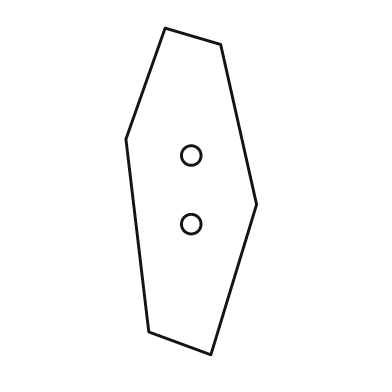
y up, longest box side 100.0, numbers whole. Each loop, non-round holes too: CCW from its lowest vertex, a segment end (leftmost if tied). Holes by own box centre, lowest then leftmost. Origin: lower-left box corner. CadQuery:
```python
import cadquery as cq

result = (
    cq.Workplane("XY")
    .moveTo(26.0, 0.0)
    .lineTo(40.0, 46.0)
    .lineTo(29.0, 95.0)
    .lineTo(12.0, 100.0)
    .lineTo(0.0, 66.0)
    .lineTo(7.0, 7.0)
    .close()
    .moveTo(20.0, 40.0)
    .circle(3.0)
    .moveTo(20.0, 61.0)
    .circle(3.0)
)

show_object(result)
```